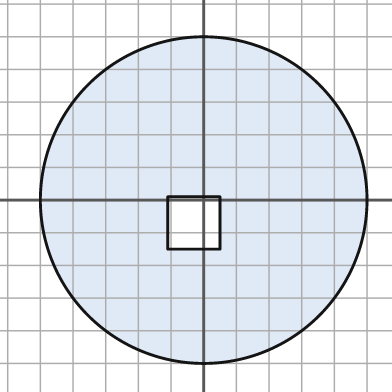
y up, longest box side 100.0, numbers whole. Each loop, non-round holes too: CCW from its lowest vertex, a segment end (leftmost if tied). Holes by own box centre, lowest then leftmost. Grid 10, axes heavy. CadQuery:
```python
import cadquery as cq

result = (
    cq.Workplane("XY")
    .moveTo(0.0, 0.0)
    .circle(50.0)
    .moveTo(-11.0, -15.0)
    .lineTo(5.0, -15.0)
    .lineTo(5.0, 1.0)
    .lineTo(-11.0, 1.0)
    .close()
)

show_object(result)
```